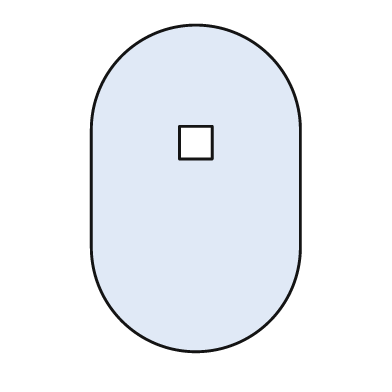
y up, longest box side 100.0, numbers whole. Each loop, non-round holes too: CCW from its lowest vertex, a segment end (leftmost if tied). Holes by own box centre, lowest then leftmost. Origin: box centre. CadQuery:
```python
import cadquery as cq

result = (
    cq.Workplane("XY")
    .moveTo(-32.0, -18.0)
    .threePointArc((0.0, -50.0), (32.0, -18.0))
    .lineTo(32.0, 18.0)
    .threePointArc((0.0, 50.0), (-32.0, 18.0))
    .close()
    .moveTo(-5.0, 9.0)
    .lineTo(5.0, 9.0)
    .lineTo(5.0, 19.0)
    .lineTo(-5.0, 19.0)
    .close()
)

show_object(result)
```